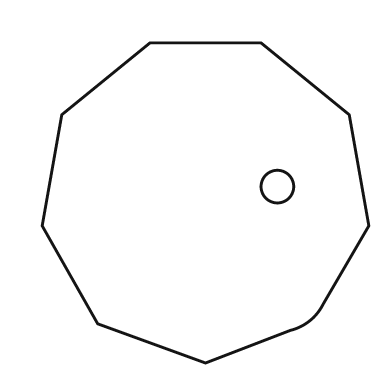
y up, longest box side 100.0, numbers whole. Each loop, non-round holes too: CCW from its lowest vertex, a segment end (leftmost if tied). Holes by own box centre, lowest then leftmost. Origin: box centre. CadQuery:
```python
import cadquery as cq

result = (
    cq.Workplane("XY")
    .moveTo(0.0, -49.0)
    .lineTo(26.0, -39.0)
    .threePointArc((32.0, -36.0), (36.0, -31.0))
    .lineTo(50.0, -7.0)
    .lineTo(44.0, 27.0)
    .lineTo(17.0, 49.0)
    .lineTo(-17.0, 49.0)
    .lineTo(-44.0, 27.0)
    .lineTo(-50.0, -7.0)
    .lineTo(-33.0, -37.0)
    .close()
    .moveTo(22.0, 5.0)
    .circle(5.0)
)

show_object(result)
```